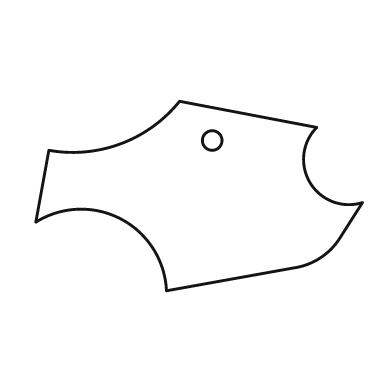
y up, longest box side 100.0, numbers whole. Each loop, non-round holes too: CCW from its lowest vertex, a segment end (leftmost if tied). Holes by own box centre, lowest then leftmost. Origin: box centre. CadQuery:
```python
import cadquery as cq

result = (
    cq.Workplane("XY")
    .moveTo(-10.0, -29.0)
    .lineTo(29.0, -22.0)
    .threePointArc((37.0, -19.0), (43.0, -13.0))
    .lineTo(50.0, -2.0)
    .threePointArc((34.0, 4.0), (36.0, 21.0))
    .lineTo(-6.0, 29.0)
    .threePointArc((-24.0, 16.0), (-46.0, 14.0))
    .lineTo(-50.0, -8.0)
    .threePointArc((-24.0, -7.0), (-10.0, -29.0))
    .close()
    .moveTo(4.0, 17.0)
    .circle(3.0)
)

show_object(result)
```